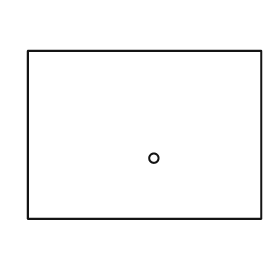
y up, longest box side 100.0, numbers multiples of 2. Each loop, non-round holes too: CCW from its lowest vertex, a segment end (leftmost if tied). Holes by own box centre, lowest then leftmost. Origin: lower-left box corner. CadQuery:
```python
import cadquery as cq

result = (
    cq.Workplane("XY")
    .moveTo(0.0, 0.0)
    .lineTo(100.0, 0.0)
    .lineTo(100.0, 72.0)
    .lineTo(0.0, 72.0)
    .close()
    .moveTo(54.0, 26.0)
    .circle(2.0)
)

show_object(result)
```